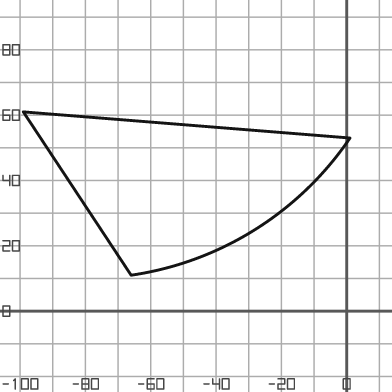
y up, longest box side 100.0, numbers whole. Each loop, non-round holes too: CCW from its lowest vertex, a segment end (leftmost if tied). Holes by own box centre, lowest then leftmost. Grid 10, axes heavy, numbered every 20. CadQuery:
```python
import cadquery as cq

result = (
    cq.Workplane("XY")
    .moveTo(-66.0, 11.0)
    .threePointArc((-28.0, 25.0), (1.0, 53.0))
    .lineTo(-99.0, 61.0)
    .close()
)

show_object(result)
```